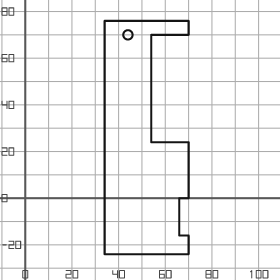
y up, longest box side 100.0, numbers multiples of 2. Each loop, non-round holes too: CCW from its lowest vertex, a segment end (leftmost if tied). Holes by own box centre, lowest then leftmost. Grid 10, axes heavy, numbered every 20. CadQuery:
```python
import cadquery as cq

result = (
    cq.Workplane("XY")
    .moveTo(34.0, -24.0)
    .lineTo(70.0, -24.0)
    .lineTo(70.0, -16.0)
    .lineTo(66.0, -16.0)
    .lineTo(66.0, 0.0)
    .lineTo(70.0, 0.0)
    .lineTo(70.0, 24.0)
    .lineTo(54.0, 24.0)
    .lineTo(54.0, 70.0)
    .lineTo(70.0, 70.0)
    .lineTo(70.0, 76.0)
    .lineTo(34.0, 76.0)
    .close()
    .moveTo(44.0, 70.0)
    .circle(2.0)
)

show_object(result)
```